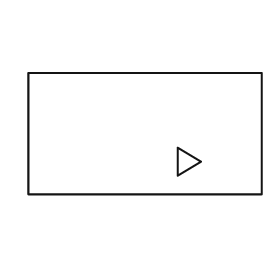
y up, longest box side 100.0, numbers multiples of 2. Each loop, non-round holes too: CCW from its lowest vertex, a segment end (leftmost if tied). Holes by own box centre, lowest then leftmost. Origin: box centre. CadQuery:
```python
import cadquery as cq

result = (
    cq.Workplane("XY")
    .moveTo(-50.0, -26.0)
    .lineTo(50.0, -26.0)
    .lineTo(50.0, 26.0)
    .lineTo(-50.0, 26.0)
    .close()
    .moveTo(14.0, -18.0)
    .lineTo(24.0, -12.0)
    .lineTo(14.0, -6.0)
    .close()
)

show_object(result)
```